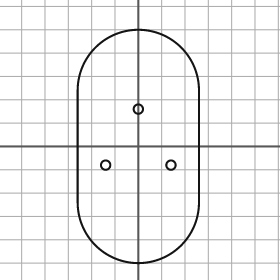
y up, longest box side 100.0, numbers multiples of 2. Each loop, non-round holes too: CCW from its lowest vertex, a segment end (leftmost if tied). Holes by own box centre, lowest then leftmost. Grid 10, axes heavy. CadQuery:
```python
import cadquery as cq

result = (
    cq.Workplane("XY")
    .moveTo(-26.0, -24.0)
    .threePointArc((0.0, -50.0), (26.0, -24.0))
    .lineTo(26.0, 24.0)
    .threePointArc((0.0, 50.0), (-26.0, 24.0))
    .close()
    .moveTo(-14.0, -8.0)
    .circle(2.0)
    .moveTo(14.0, -8.0)
    .circle(2.0)
    .moveTo(0.0, 16.0)
    .circle(2.0)
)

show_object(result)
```